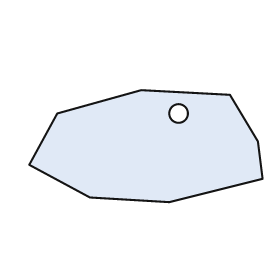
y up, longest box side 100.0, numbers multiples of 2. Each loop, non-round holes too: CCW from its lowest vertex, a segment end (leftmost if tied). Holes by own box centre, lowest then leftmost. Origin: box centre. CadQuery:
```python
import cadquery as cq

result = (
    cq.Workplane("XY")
    .moveTo(10.0, -24.0)
    .lineTo(50.0, -14.0)
    .lineTo(48.0, 2.0)
    .lineTo(36.0, 22.0)
    .lineTo(-2.0, 24.0)
    .lineTo(-38.0, 14.0)
    .lineTo(-50.0, -8.0)
    .lineTo(-24.0, -22.0)
    .close()
    .moveTo(14.0, 14.0)
    .circle(4.0)
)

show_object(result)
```